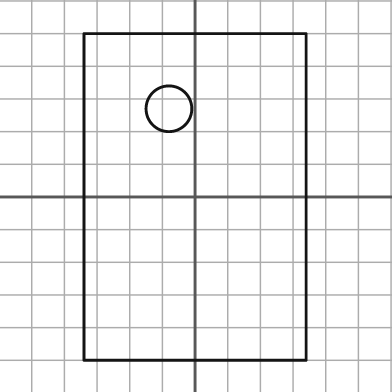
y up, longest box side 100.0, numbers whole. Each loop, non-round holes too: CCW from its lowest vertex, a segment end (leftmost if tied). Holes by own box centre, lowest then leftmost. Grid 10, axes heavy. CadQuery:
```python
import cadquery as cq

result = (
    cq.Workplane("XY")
    .moveTo(-34.0, -50.0)
    .lineTo(34.0, -50.0)
    .lineTo(34.0, 50.0)
    .lineTo(-34.0, 50.0)
    .close()
    .moveTo(-8.0, 27.0)
    .circle(7.0)
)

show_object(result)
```